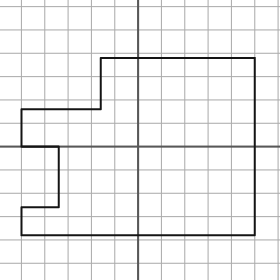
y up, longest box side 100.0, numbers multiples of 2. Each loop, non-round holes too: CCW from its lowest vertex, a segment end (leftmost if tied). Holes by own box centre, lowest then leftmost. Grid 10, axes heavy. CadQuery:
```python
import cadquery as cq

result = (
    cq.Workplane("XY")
    .moveTo(-50.0, -38.0)
    .lineTo(50.0, -38.0)
    .lineTo(50.0, 38.0)
    .lineTo(-16.0, 38.0)
    .lineTo(-16.0, 16.0)
    .lineTo(-50.0, 16.0)
    .lineTo(-50.0, 0.0)
    .lineTo(-34.0, 0.0)
    .lineTo(-34.0, -26.0)
    .lineTo(-50.0, -26.0)
    .close()
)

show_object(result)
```